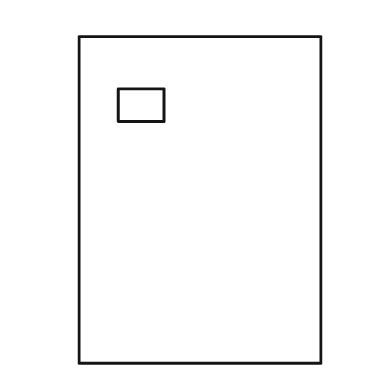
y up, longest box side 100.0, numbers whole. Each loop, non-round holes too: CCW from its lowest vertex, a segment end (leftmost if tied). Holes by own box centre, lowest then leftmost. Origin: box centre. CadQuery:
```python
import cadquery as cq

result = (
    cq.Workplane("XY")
    .moveTo(-37.0, -50.0)
    .lineTo(37.0, -50.0)
    .lineTo(37.0, 50.0)
    .lineTo(-37.0, 50.0)
    .close()
    .moveTo(-25.0, 24.0)
    .lineTo(-11.0, 24.0)
    .lineTo(-11.0, 34.0)
    .lineTo(-25.0, 34.0)
    .close()
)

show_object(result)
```